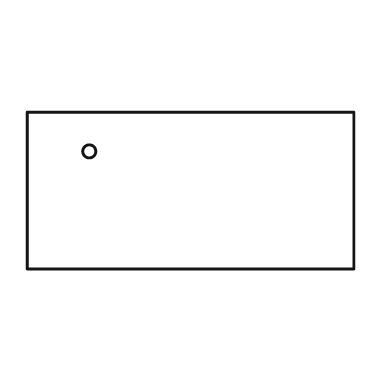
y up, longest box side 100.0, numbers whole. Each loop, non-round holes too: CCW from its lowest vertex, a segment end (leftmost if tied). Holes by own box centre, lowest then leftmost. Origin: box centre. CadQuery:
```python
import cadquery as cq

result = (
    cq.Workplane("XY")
    .moveTo(-50.0, -24.0)
    .lineTo(50.0, -24.0)
    .lineTo(50.0, 24.0)
    .lineTo(-50.0, 24.0)
    .close()
    .moveTo(-31.0, 12.0)
    .circle(2.0)
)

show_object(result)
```